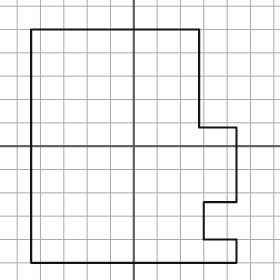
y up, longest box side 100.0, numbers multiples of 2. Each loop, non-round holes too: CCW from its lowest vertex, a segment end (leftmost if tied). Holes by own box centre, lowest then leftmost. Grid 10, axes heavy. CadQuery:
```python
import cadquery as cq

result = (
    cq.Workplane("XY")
    .moveTo(-44.0, -50.0)
    .lineTo(44.0, -50.0)
    .lineTo(44.0, -40.0)
    .lineTo(30.0, -40.0)
    .lineTo(30.0, -24.0)
    .lineTo(44.0, -24.0)
    .lineTo(44.0, 8.0)
    .lineTo(28.0, 8.0)
    .lineTo(28.0, 50.0)
    .lineTo(-44.0, 50.0)
    .close()
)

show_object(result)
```